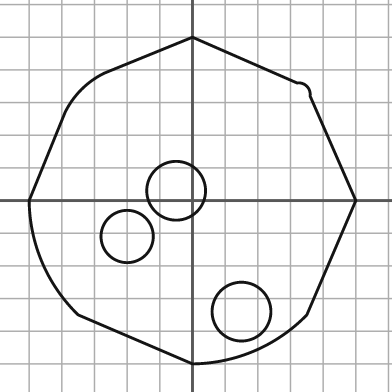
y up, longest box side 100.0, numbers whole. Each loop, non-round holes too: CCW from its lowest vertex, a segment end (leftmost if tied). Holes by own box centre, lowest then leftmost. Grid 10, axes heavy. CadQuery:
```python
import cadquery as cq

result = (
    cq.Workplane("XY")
    .moveTo(0.0, -50.0)
    .threePointArc((19.0, -46.0), (35.0, -35.0))
    .lineTo(50.0, 0.0)
    .lineTo(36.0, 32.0)
    .threePointArc((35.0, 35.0), (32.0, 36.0))
    .lineTo(0.0, 50.0)
    .lineTo(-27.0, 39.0)
    .threePointArc((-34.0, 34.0), (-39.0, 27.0))
    .lineTo(-50.0, 0.0)
    .threePointArc((-46.0, -19.0), (-35.0, -35.0))
    .close()
    .moveTo(15.0, -34.0)
    .circle(9.0)
    .moveTo(-20.0, -11.0)
    .circle(8.0)
    .moveTo(-5.0, 3.0)
    .circle(9.0)
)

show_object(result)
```